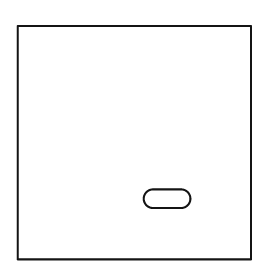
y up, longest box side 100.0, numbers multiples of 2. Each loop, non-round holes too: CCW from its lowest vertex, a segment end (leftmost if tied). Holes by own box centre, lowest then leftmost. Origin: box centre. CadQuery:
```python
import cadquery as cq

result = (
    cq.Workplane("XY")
    .moveTo(-50.0, -50.0)
    .lineTo(50.0, -50.0)
    .lineTo(50.0, 50.0)
    .lineTo(-50.0, 50.0)
    .close()
    .moveTo(8.0, -28.0)
    .lineTo(20.0, -28.0)
    .threePointArc((24.0, -24.0), (20.0, -20.0))
    .lineTo(8.0, -20.0)
    .threePointArc((4.0, -24.0), (8.0, -28.0))
    .close()
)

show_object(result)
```